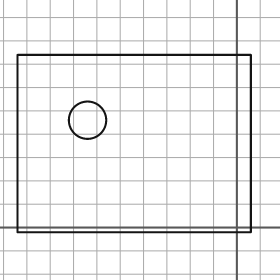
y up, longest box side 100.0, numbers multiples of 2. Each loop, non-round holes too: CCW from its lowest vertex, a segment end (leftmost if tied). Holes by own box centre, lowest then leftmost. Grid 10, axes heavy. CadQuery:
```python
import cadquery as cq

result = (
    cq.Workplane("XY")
    .moveTo(-94.0, -2.0)
    .lineTo(6.0, -2.0)
    .lineTo(6.0, 74.0)
    .lineTo(-94.0, 74.0)
    .close()
    .moveTo(-64.0, 46.0)
    .circle(8.0)
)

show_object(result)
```